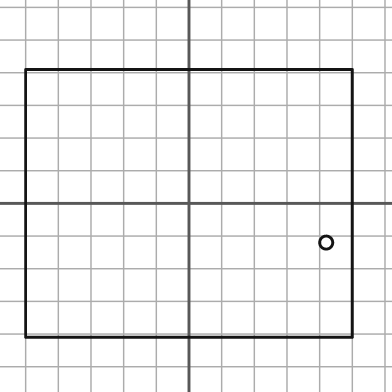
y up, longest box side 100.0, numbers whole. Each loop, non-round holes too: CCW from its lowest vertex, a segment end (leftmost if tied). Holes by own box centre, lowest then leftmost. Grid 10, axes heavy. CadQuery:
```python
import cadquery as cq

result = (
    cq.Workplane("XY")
    .moveTo(-50.0, -41.0)
    .lineTo(50.0, -41.0)
    .lineTo(50.0, 41.0)
    .lineTo(-50.0, 41.0)
    .close()
    .moveTo(42.0, -12.0)
    .circle(2.0)
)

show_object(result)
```